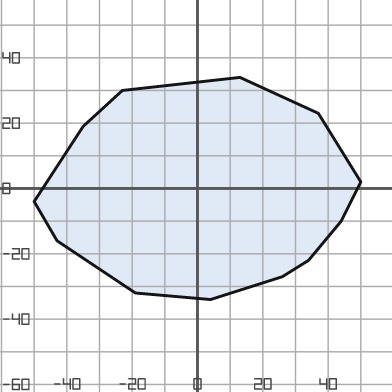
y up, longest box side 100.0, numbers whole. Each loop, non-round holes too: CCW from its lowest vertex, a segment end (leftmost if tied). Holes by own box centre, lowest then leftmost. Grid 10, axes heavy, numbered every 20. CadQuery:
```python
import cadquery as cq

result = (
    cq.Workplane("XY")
    .moveTo(4.0, -34.0)
    .lineTo(26.0, -27.0)
    .lineTo(34.0, -22.0)
    .lineTo(44.0, -10.0)
    .lineTo(50.0, 2.0)
    .lineTo(37.0, 23.0)
    .lineTo(13.0, 34.0)
    .lineTo(-23.0, 30.0)
    .lineTo(-35.0, 19.0)
    .lineTo(-50.0, -4.0)
    .lineTo(-43.0, -16.0)
    .lineTo(-19.0, -32.0)
    .close()
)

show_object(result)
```